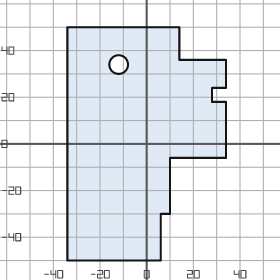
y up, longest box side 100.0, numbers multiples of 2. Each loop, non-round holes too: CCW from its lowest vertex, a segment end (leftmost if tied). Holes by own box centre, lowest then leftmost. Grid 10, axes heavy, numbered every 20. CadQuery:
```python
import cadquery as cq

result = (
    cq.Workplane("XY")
    .moveTo(-34.0, -50.0)
    .lineTo(6.0, -50.0)
    .lineTo(6.0, -30.0)
    .lineTo(10.0, -30.0)
    .lineTo(10.0, -6.0)
    .lineTo(34.0, -6.0)
    .lineTo(34.0, 18.0)
    .lineTo(28.0, 18.0)
    .lineTo(28.0, 24.0)
    .lineTo(34.0, 24.0)
    .lineTo(34.0, 36.0)
    .lineTo(14.0, 36.0)
    .lineTo(14.0, 50.0)
    .lineTo(-34.0, 50.0)
    .close()
    .moveTo(-12.0, 34.0)
    .circle(4.0)
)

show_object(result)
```